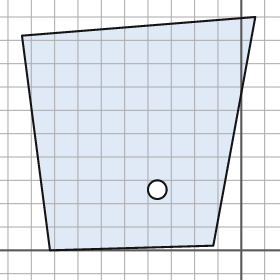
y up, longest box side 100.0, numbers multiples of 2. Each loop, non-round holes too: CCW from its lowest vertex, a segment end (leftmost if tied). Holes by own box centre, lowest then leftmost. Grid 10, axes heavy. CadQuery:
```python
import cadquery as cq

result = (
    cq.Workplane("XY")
    .moveTo(-82.0, 0.0)
    .lineTo(-12.0, 2.0)
    .lineTo(6.0, 100.0)
    .lineTo(-94.0, 92.0)
    .close()
    .moveTo(-36.0, 26.0)
    .circle(4.0)
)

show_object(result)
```